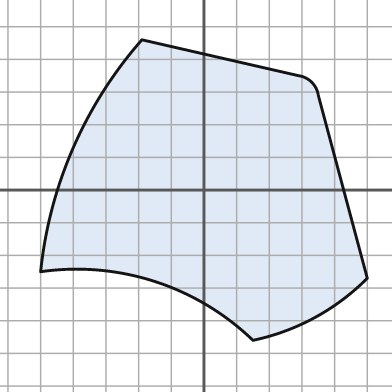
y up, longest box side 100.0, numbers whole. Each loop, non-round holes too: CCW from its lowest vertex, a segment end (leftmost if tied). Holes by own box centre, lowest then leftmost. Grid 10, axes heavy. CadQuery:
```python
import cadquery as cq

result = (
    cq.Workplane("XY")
    .moveTo(15.0, -46.0)
    .threePointArc((34.0, -39.0), (50.0, -27.0))
    .lineTo(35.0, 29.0)
    .threePointArc((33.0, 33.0), (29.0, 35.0))
    .lineTo(-19.0, 46.0)
    .threePointArc((-40.0, 13.0), (-50.0, -25.0))
    .threePointArc((-15.0, -28.0), (15.0, -46.0))
    .close()
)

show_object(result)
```